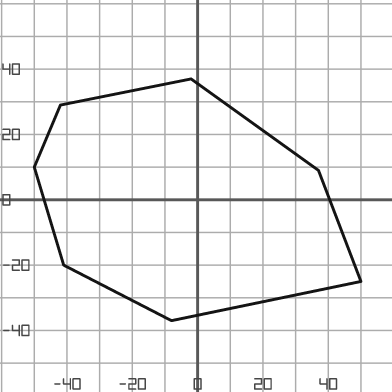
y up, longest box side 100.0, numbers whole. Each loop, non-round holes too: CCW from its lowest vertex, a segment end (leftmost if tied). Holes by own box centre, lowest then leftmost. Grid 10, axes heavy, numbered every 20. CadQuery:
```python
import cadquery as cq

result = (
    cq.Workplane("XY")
    .moveTo(-8.0, -37.0)
    .lineTo(50.0, -25.0)
    .lineTo(37.0, 9.0)
    .lineTo(-2.0, 37.0)
    .lineTo(-42.0, 29.0)
    .lineTo(-50.0, 10.0)
    .lineTo(-41.0, -20.0)
    .close()
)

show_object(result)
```